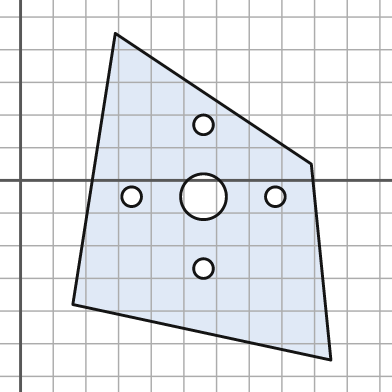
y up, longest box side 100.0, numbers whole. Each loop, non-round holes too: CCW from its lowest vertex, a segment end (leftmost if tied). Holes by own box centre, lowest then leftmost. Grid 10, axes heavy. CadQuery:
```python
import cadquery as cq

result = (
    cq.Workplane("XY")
    .moveTo(95.0, -55.0)
    .lineTo(89.0, 5.0)
    .lineTo(29.0, 45.0)
    .lineTo(16.0, -38.0)
    .close()
    .moveTo(56.0, -27.0)
    .circle(3.0)
    .moveTo(34.0, -5.0)
    .circle(3.0)
    .moveTo(56.0, -5.0)
    .circle(7.0)
    .moveTo(78.0, -5.0)
    .circle(3.0)
    .moveTo(56.0, 17.0)
    .circle(3.0)
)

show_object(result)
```